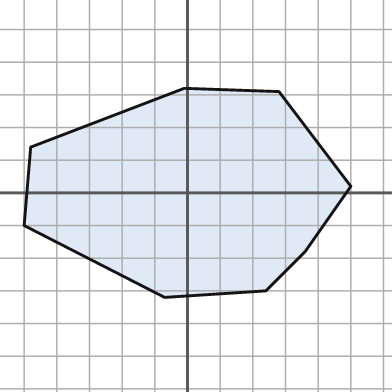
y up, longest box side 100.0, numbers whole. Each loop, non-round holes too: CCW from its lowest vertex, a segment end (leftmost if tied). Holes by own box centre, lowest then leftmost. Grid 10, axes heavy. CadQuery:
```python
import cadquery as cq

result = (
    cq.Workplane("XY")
    .moveTo(-7.0, -32.0)
    .lineTo(24.0, -30.0)
    .lineTo(36.0, -18.0)
    .lineTo(50.0, 2.0)
    .lineTo(28.0, 31.0)
    .lineTo(-1.0, 32.0)
    .lineTo(-48.0, 14.0)
    .lineTo(-50.0, -10.0)
    .close()
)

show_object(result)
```